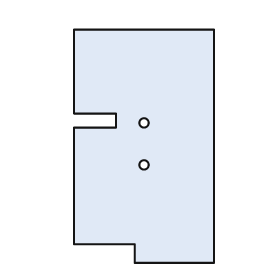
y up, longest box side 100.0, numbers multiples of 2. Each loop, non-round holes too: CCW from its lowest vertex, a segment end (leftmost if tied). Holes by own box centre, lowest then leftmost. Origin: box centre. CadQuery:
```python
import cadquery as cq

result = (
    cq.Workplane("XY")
    .moveTo(-4.0, -50.0)
    .lineTo(30.0, -50.0)
    .lineTo(30.0, 50.0)
    .lineTo(-30.0, 50.0)
    .lineTo(-30.0, 14.0)
    .lineTo(-12.0, 14.0)
    .lineTo(-12.0, 8.0)
    .lineTo(-30.0, 8.0)
    .lineTo(-30.0, -42.0)
    .lineTo(-4.0, -42.0)
    .close()
    .moveTo(0.0, -8.0)
    .circle(2.0)
    .moveTo(0.0, 10.0)
    .circle(2.0)
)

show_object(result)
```